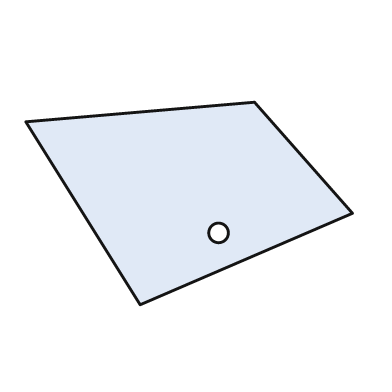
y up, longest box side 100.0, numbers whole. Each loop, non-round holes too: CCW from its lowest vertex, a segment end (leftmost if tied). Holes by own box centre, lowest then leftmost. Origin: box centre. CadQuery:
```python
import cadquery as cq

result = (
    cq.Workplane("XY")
    .moveTo(-15.0, -31.0)
    .lineTo(50.0, -3.0)
    .lineTo(20.0, 31.0)
    .lineTo(-50.0, 25.0)
    .close()
    .moveTo(9.0, -9.0)
    .circle(3.0)
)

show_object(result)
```